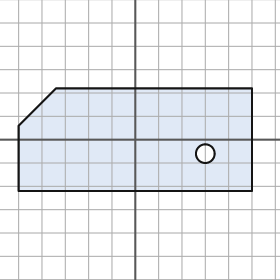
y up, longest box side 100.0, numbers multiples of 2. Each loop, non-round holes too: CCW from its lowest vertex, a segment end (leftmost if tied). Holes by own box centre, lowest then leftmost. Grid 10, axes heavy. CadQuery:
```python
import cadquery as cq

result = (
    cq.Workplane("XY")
    .moveTo(-50.0, -22.0)
    .lineTo(50.0, -22.0)
    .lineTo(50.0, 22.0)
    .lineTo(-34.0, 22.0)
    .lineTo(-50.0, 6.0)
    .close()
    .moveTo(30.0, -6.0)
    .circle(4.0)
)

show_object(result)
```